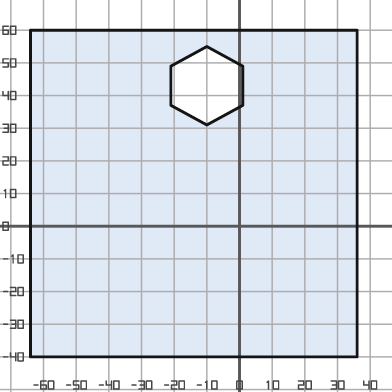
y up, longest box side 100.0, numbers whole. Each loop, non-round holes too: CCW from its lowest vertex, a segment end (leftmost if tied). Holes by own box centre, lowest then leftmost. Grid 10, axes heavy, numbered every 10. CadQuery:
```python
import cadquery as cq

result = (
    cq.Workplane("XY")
    .moveTo(-64.0, -40.0)
    .lineTo(36.0, -40.0)
    .lineTo(36.0, 60.0)
    .lineTo(-64.0, 60.0)
    .close()
    .moveTo(-10.0, 31.0)
    .lineTo(1.0, 37.0)
    .lineTo(1.0, 49.0)
    .lineTo(-10.0, 55.0)
    .lineTo(-21.0, 49.0)
    .lineTo(-21.0, 37.0)
    .close()
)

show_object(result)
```